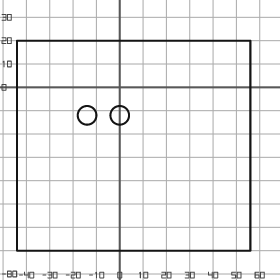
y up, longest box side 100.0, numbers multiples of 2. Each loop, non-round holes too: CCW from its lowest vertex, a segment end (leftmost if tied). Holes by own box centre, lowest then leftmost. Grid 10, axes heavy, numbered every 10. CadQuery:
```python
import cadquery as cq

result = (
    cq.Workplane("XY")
    .moveTo(-44.0, -70.0)
    .lineTo(56.0, -70.0)
    .lineTo(56.0, 20.0)
    .lineTo(-44.0, 20.0)
    .close()
    .moveTo(-14.0, -12.0)
    .circle(4.0)
    .moveTo(0.0, -12.0)
    .circle(4.0)
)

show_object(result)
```